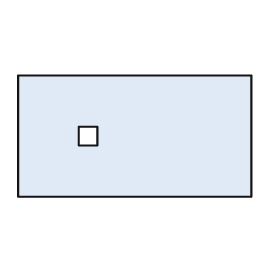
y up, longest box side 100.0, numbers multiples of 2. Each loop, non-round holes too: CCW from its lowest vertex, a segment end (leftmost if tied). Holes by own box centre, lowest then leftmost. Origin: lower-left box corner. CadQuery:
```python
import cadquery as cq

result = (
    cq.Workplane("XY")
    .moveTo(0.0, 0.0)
    .lineTo(100.0, 0.0)
    .lineTo(100.0, 52.0)
    .lineTo(0.0, 52.0)
    .close()
    .moveTo(26.0, 22.0)
    .lineTo(34.0, 22.0)
    .lineTo(34.0, 30.0)
    .lineTo(26.0, 30.0)
    .close()
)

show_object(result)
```